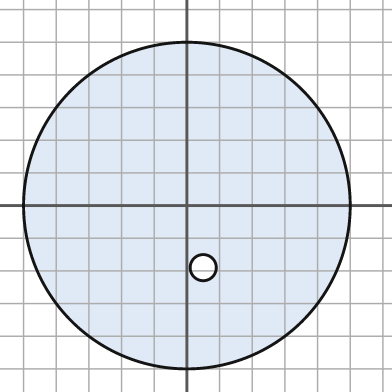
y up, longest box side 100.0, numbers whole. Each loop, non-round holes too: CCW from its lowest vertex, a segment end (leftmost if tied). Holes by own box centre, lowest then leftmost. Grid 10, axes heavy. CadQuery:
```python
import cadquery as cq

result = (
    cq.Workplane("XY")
    .moveTo(0.0, 0.0)
    .circle(50.0)
    .moveTo(5.0, -19.0)
    .circle(4.0)
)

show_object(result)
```